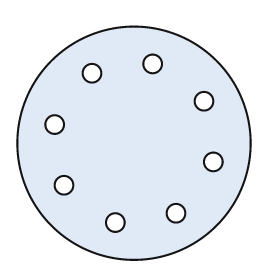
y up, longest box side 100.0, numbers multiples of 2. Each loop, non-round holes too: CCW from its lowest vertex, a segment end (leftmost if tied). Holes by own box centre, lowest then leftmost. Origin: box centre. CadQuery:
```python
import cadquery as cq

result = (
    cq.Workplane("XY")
    .moveTo(0.0, 0.0)
    .circle(50.0)
    .moveTo(-8.0, -34.0)
    .circle(4.0)
    .moveTo(18.0, -30.0)
    .circle(4.0)
    .moveTo(-30.0, -18.0)
    .circle(4.0)
    .moveTo(34.0, -8.0)
    .circle(4.0)
    .moveTo(-34.0, 8.0)
    .circle(4.0)
    .moveTo(30.0, 18.0)
    .circle(4.0)
    .moveTo(-18.0, 30.0)
    .circle(4.0)
    .moveTo(8.0, 34.0)
    .circle(4.0)
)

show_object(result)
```